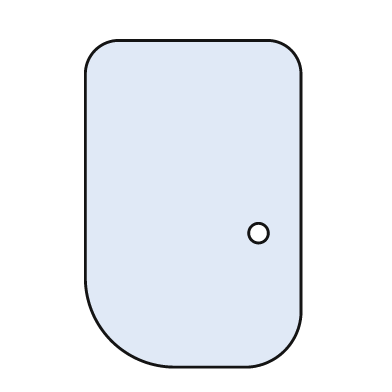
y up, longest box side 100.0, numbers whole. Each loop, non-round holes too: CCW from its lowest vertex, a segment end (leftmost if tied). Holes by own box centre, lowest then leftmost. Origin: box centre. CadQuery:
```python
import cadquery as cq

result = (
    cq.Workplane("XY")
    .moveTo(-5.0, -50.0)
    .lineTo(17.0, -50.0)
    .threePointArc((28.0, -45.0), (33.0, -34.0))
    .lineTo(33.0, 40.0)
    .threePointArc((30.0, 47.0), (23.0, 50.0))
    .lineTo(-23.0, 50.0)
    .threePointArc((-30.0, 47.0), (-33.0, 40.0))
    .lineTo(-33.0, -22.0)
    .threePointArc((-25.0, -42.0), (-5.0, -50.0))
    .close()
    .moveTo(20.0, -9.0)
    .circle(3.0)
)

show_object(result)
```